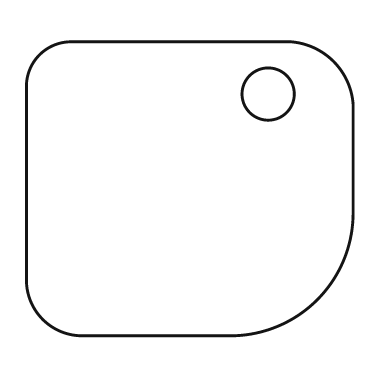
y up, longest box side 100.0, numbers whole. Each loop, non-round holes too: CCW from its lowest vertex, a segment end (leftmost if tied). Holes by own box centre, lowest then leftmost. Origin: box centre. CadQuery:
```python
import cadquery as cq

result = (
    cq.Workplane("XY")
    .moveTo(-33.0, -45.0)
    .lineTo(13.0, -45.0)
    .threePointArc((39.0, -34.0), (50.0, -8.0))
    .lineTo(50.0, 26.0)
    .threePointArc((44.0, 39.0), (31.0, 45.0))
    .lineTo(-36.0, 45.0)
    .threePointArc((-46.0, 41.0), (-50.0, 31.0))
    .lineTo(-50.0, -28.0)
    .threePointArc((-45.0, -40.0), (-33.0, -45.0))
    .close()
    .moveTo(24.0, 29.0)
    .circle(8.0)
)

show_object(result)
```